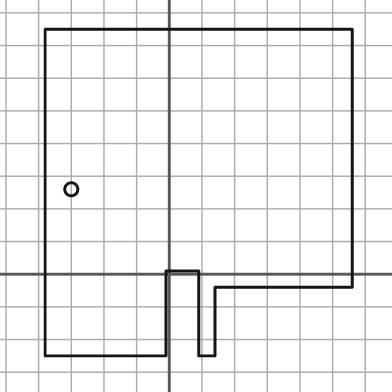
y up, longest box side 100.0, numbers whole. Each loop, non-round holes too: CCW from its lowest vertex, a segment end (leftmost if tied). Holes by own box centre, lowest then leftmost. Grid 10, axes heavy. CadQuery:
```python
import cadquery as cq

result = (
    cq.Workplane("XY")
    .moveTo(-38.0, -25.0)
    .lineTo(-1.0, -25.0)
    .lineTo(-1.0, 1.0)
    .lineTo(9.0, 1.0)
    .lineTo(9.0, -25.0)
    .lineTo(14.0, -25.0)
    .lineTo(14.0, -4.0)
    .lineTo(56.0, -4.0)
    .lineTo(56.0, 75.0)
    .lineTo(-38.0, 75.0)
    .close()
    .moveTo(-30.0, 26.0)
    .circle(2.0)
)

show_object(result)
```